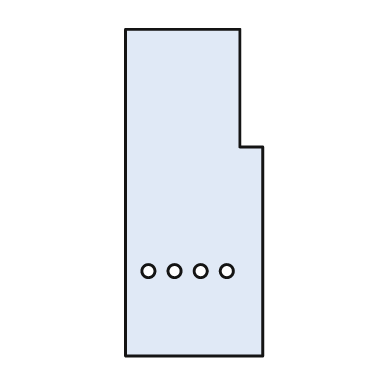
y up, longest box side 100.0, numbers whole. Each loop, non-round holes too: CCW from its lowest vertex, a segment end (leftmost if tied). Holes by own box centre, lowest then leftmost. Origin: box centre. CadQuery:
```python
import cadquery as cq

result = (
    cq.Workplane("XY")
    .moveTo(-21.0, -50.0)
    .lineTo(21.0, -50.0)
    .lineTo(21.0, 14.0)
    .lineTo(14.0, 14.0)
    .lineTo(14.0, 50.0)
    .lineTo(-21.0, 50.0)
    .close()
    .moveTo(-14.0, -24.0)
    .circle(2.0)
    .moveTo(-6.0, -24.0)
    .circle(2.0)
    .moveTo(2.0, -24.0)
    .circle(2.0)
    .moveTo(10.0, -24.0)
    .circle(2.0)
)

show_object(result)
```